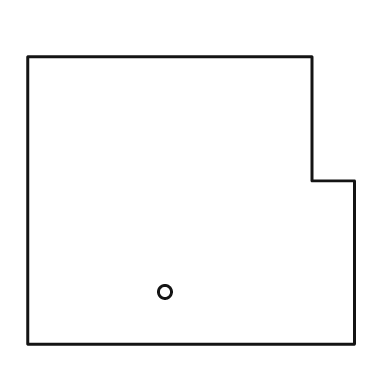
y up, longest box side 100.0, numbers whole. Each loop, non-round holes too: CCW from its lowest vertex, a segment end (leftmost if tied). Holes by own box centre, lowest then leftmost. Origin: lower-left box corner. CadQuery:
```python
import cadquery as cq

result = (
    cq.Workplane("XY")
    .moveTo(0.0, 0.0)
    .lineTo(100.0, 0.0)
    .lineTo(100.0, 50.0)
    .lineTo(87.0, 50.0)
    .lineTo(87.0, 88.0)
    .lineTo(0.0, 88.0)
    .close()
    .moveTo(42.0, 16.0)
    .circle(2.0)
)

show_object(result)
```